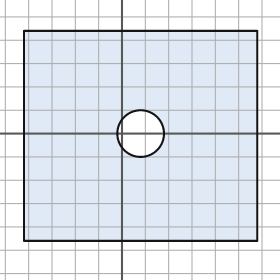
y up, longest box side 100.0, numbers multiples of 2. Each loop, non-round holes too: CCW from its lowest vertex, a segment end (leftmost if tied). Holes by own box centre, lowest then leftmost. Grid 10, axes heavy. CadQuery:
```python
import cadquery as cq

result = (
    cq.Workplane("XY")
    .moveTo(-42.0, -46.0)
    .lineTo(58.0, -46.0)
    .lineTo(58.0, 44.0)
    .lineTo(-42.0, 44.0)
    .close()
    .moveTo(8.0, 0.0)
    .circle(10.0)
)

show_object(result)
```